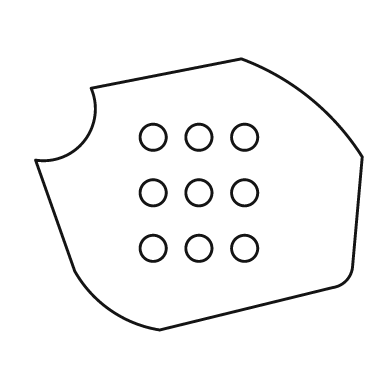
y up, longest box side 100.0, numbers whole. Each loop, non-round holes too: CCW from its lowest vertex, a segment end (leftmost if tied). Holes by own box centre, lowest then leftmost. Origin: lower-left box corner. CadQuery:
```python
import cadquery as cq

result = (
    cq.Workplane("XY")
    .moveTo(38.0, 0.0)
    .lineTo(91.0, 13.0)
    .threePointArc((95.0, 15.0), (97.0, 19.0))
    .lineTo(100.0, 53.0)
    .threePointArc((84.0, 71.0), (63.0, 83.0))
    .lineTo(17.0, 74.0)
    .threePointArc((15.0, 58.0), (0.0, 52.0))
    .lineTo(12.0, 18.0)
    .threePointArc((23.0, 6.0), (38.0, 0.0))
    .close()
    .moveTo(36.0, 25.0)
    .circle(4.0)
    .moveTo(50.0, 25.0)
    .circle(4.0)
    .moveTo(64.0, 25.0)
    .circle(4.0)
    .moveTo(36.0, 42.0)
    .circle(4.0)
    .moveTo(50.0, 42.0)
    .circle(4.0)
    .moveTo(64.0, 42.0)
    .circle(4.0)
    .moveTo(36.0, 59.0)
    .circle(4.0)
    .moveTo(50.0, 59.0)
    .circle(4.0)
    .moveTo(64.0, 59.0)
    .circle(4.0)
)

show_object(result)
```